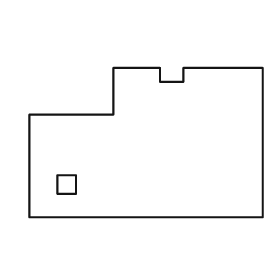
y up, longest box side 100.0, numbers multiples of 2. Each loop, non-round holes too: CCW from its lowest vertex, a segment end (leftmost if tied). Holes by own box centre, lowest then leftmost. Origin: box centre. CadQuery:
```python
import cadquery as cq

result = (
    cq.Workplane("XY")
    .moveTo(-50.0, -32.0)
    .lineTo(50.0, -32.0)
    .lineTo(50.0, 32.0)
    .lineTo(16.0, 32.0)
    .lineTo(16.0, 26.0)
    .lineTo(6.0, 26.0)
    .lineTo(6.0, 32.0)
    .lineTo(-14.0, 32.0)
    .lineTo(-14.0, 12.0)
    .lineTo(-50.0, 12.0)
    .close()
    .moveTo(-38.0, -22.0)
    .lineTo(-30.0, -22.0)
    .lineTo(-30.0, -14.0)
    .lineTo(-38.0, -14.0)
    .close()
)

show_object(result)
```